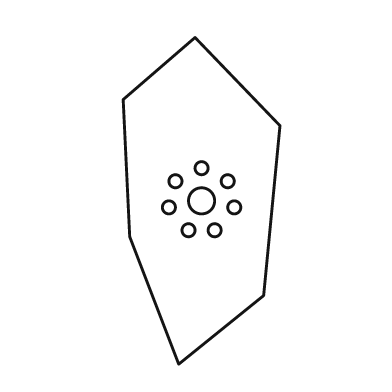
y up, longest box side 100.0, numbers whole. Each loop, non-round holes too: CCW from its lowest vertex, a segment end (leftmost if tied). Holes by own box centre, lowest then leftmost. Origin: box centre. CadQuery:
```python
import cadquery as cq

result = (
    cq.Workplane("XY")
    .moveTo(-7.0, -50.0)
    .lineTo(19.0, -29.0)
    .lineTo(24.0, 23.0)
    .lineTo(-2.0, 50.0)
    .lineTo(-24.0, 31.0)
    .lineTo(-22.0, -11.0)
    .close()
    .moveTo(-4.0, -9.0)
    .circle(2.0)
    .moveTo(4.0, -9.0)
    .circle(2.0)
    .moveTo(-10.0, -2.0)
    .circle(2.0)
    .moveTo(10.0, -2.0)
    .circle(2.0)
    .moveTo(0.0, 0.0)
    .circle(4.0)
    .moveTo(-8.0, 6.0)
    .circle(2.0)
    .moveTo(8.0, 6.0)
    .circle(2.0)
    .moveTo(0.0, 10.0)
    .circle(2.0)
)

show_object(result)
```